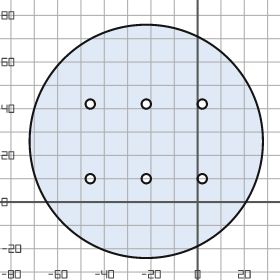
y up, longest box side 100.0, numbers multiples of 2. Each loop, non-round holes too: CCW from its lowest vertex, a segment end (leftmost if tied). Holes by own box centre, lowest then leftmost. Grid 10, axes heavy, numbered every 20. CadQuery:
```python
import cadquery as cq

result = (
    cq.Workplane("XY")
    .moveTo(-22.0, 26.0)
    .circle(50.0)
    .moveTo(-46.0, 10.0)
    .circle(2.0)
    .moveTo(-22.0, 10.0)
    .circle(2.0)
    .moveTo(2.0, 10.0)
    .circle(2.0)
    .moveTo(-46.0, 42.0)
    .circle(2.0)
    .moveTo(-22.0, 42.0)
    .circle(2.0)
    .moveTo(2.0, 42.0)
    .circle(2.0)
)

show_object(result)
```